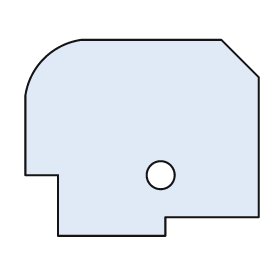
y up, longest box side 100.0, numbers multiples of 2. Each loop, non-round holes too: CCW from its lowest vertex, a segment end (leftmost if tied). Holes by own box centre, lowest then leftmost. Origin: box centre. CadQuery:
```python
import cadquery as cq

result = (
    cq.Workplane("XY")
    .moveTo(-36.0, -42.0)
    .lineTo(10.0, -42.0)
    .lineTo(10.0, -34.0)
    .lineTo(50.0, -34.0)
    .lineTo(50.0, 26.0)
    .lineTo(34.0, 42.0)
    .lineTo(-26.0, 42.0)
    .threePointArc((-42.0, 34.0), (-50.0, 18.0))
    .lineTo(-50.0, -16.0)
    .lineTo(-36.0, -16.0)
    .close()
    .moveTo(8.0, -16.0)
    .circle(6.0)
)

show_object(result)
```